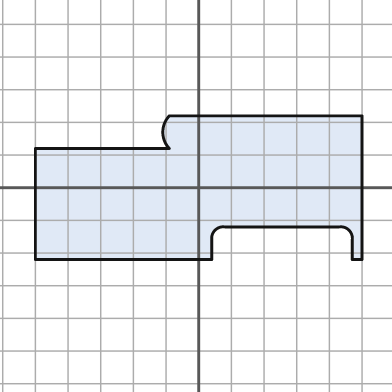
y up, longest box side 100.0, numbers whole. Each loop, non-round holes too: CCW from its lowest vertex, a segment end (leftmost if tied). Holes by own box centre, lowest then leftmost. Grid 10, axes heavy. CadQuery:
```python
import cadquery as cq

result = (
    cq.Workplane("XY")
    .moveTo(-50.0, -22.0)
    .lineTo(4.0, -22.0)
    .lineTo(4.0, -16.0)
    .threePointArc((5.0, -13.0), (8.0, -12.0))
    .lineTo(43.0, -12.0)
    .threePointArc((46.0, -13.0), (47.0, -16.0))
    .lineTo(47.0, -22.0)
    .lineTo(50.0, -22.0)
    .lineTo(50.0, 22.0)
    .lineTo(-9.0, 22.0)
    .threePointArc((-11.0, 17.0), (-9.0, 12.0))
    .lineTo(-50.0, 12.0)
    .close()
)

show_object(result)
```